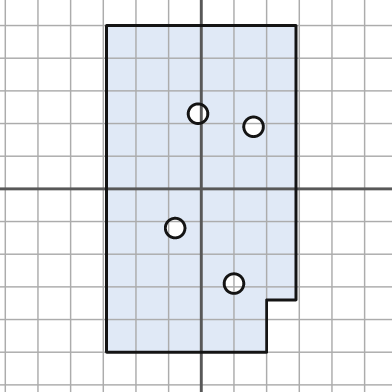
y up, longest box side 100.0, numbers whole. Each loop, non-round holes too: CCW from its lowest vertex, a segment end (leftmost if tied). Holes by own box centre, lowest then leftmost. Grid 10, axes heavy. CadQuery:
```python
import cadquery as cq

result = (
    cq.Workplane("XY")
    .moveTo(-29.0, -50.0)
    .lineTo(20.0, -50.0)
    .lineTo(20.0, -34.0)
    .lineTo(29.0, -34.0)
    .lineTo(29.0, 50.0)
    .lineTo(-29.0, 50.0)
    .close()
    .moveTo(10.0, -29.0)
    .circle(3.0)
    .moveTo(-8.0, -12.0)
    .circle(3.0)
    .moveTo(16.0, 19.0)
    .circle(3.0)
    .moveTo(-1.0, 23.0)
    .circle(3.0)
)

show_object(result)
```